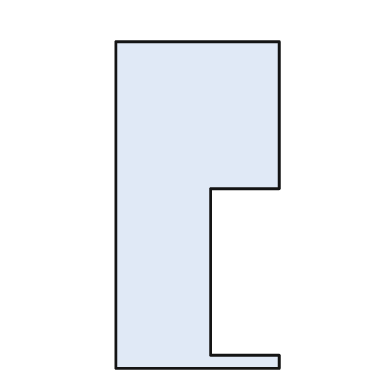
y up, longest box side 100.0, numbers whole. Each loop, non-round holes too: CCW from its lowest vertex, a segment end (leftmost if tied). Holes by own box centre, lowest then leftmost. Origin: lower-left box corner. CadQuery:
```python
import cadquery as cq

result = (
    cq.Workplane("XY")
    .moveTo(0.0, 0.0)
    .lineTo(50.0, 0.0)
    .lineTo(50.0, 4.0)
    .lineTo(29.0, 4.0)
    .lineTo(29.0, 55.0)
    .lineTo(50.0, 55.0)
    .lineTo(50.0, 100.0)
    .lineTo(0.0, 100.0)
    .close()
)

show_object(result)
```